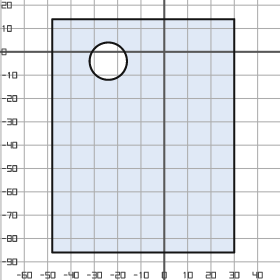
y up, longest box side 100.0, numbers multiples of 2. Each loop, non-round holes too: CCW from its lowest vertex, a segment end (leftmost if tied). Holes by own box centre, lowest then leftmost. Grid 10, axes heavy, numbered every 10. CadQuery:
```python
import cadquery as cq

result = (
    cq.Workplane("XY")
    .moveTo(-48.0, -86.0)
    .lineTo(30.0, -86.0)
    .lineTo(30.0, 14.0)
    .lineTo(-48.0, 14.0)
    .close()
    .moveTo(-24.0, -4.0)
    .circle(8.0)
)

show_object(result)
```